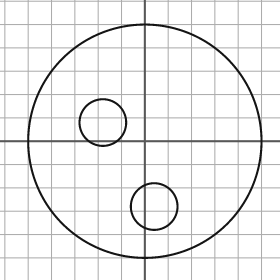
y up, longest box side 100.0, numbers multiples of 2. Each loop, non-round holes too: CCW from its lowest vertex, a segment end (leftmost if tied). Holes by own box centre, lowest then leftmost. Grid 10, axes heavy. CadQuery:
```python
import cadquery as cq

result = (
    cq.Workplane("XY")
    .moveTo(0.0, 0.0)
    .circle(50.0)
    .moveTo(4.0, -28.0)
    .circle(10.0)
    .moveTo(-18.0, 8.0)
    .circle(10.0)
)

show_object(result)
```